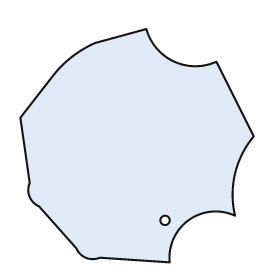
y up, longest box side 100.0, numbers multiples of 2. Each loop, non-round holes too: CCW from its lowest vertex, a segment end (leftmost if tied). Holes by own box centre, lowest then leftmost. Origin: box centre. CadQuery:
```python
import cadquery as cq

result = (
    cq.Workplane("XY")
    .moveTo(14.0, -50.0)
    .threePointArc((22.0, -32.0), (42.0, -30.0))
    .threePointArc((42.0, -12.0), (50.0, 4.0))
    .lineTo(34.0, 36.0)
    .threePointArc((16.0, 36.0), (4.0, 50.0))
    .lineTo(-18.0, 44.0)
    .threePointArc((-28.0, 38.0), (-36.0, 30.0))
    .lineTo(-50.0, 12.0)
    .lineTo(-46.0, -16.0)
    .threePointArc((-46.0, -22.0), (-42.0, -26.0))
    .lineTo(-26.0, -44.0)
    .threePointArc((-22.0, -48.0), (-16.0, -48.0))
    .close()
    .moveTo(12.0, -32.0)
    .circle(2.0)
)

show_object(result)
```